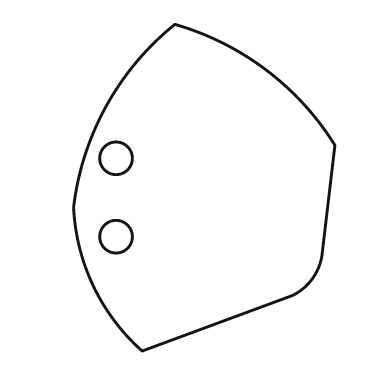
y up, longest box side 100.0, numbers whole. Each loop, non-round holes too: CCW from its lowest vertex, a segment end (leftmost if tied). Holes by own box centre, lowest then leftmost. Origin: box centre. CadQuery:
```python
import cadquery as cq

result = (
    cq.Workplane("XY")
    .moveTo(-19.0, -50.0)
    .lineTo(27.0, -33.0)
    .threePointArc((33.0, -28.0), (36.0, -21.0))
    .lineTo(40.0, 13.0)
    .threePointArc((19.0, 36.0), (-9.0, 50.0))
    .threePointArc((-30.0, 25.0), (-40.0, -6.0))
    .threePointArc((-34.0, -30.0), (-19.0, -50.0))
    .close()
    .moveTo(-27.0, -15.0)
    .circle(5.0)
    .moveTo(-27.0, 9.0)
    .circle(5.0)
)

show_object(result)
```